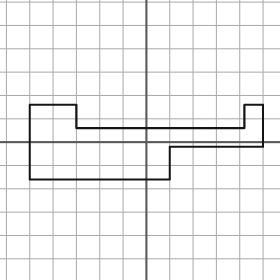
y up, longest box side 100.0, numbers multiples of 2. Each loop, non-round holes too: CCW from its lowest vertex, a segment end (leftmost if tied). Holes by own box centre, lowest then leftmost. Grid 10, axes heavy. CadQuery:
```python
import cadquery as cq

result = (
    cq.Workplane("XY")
    .moveTo(-50.0, -16.0)
    .lineTo(10.0, -16.0)
    .lineTo(10.0, -2.0)
    .lineTo(50.0, -2.0)
    .lineTo(50.0, 16.0)
    .lineTo(42.0, 16.0)
    .lineTo(42.0, 6.0)
    .lineTo(-30.0, 6.0)
    .lineTo(-30.0, 16.0)
    .lineTo(-50.0, 16.0)
    .close()
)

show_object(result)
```